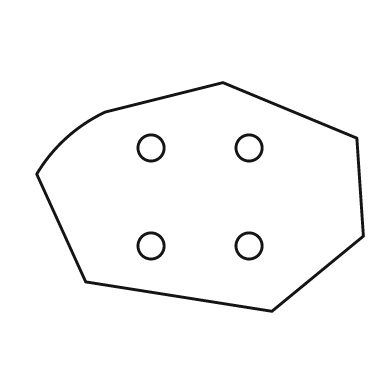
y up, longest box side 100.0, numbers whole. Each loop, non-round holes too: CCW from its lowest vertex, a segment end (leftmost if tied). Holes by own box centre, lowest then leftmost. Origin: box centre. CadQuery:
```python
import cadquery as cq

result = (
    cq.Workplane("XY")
    .moveTo(22.0, -35.0)
    .lineTo(50.0, -12.0)
    .lineTo(48.0, 18.0)
    .lineTo(7.0, 35.0)
    .lineTo(-29.0, 26.0)
    .threePointArc((-41.0, 18.0), (-50.0, 7.0))
    .lineTo(-35.0, -26.0)
    .close()
    .moveTo(-15.0, -15.0)
    .circle(4.0)
    .moveTo(15.0, -15.0)
    .circle(4.0)
    .moveTo(-15.0, 15.0)
    .circle(4.0)
    .moveTo(15.0, 15.0)
    .circle(4.0)
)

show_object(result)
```